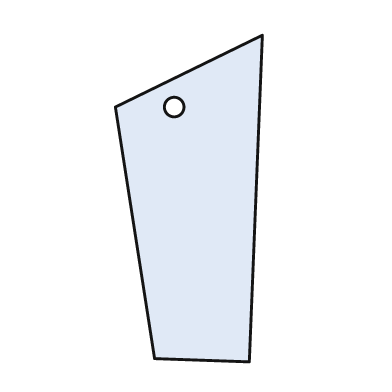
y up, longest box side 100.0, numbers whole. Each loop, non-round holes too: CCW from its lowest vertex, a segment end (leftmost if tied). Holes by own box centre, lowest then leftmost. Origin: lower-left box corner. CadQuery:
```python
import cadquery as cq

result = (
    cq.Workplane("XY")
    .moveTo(41.0, 0.0)
    .lineTo(45.0, 100.0)
    .lineTo(0.0, 78.0)
    .lineTo(12.0, 1.0)
    .close()
    .moveTo(18.0, 78.0)
    .circle(3.0)
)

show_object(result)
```